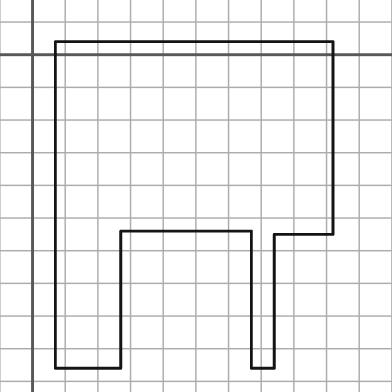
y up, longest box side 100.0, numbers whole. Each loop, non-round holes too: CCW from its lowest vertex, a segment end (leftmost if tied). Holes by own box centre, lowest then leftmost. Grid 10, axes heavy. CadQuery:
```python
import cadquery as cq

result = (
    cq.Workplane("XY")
    .moveTo(7.0, -96.0)
    .lineTo(27.0, -96.0)
    .lineTo(27.0, -54.0)
    .lineTo(67.0, -54.0)
    .lineTo(67.0, -96.0)
    .lineTo(74.0, -96.0)
    .lineTo(74.0, -55.0)
    .lineTo(92.0, -55.0)
    .lineTo(92.0, 4.0)
    .lineTo(7.0, 4.0)
    .close()
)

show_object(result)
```